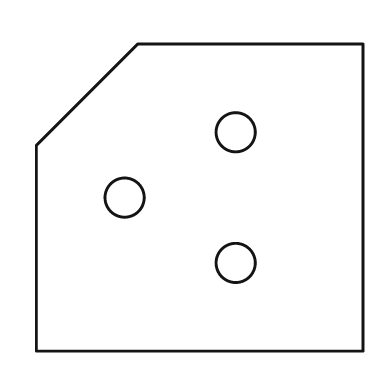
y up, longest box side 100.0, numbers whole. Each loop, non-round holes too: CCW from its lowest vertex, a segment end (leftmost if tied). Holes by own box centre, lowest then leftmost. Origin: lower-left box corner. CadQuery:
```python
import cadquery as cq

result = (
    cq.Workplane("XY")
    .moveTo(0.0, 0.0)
    .lineTo(100.0, 0.0)
    .lineTo(100.0, 94.0)
    .lineTo(31.0, 94.0)
    .lineTo(0.0, 63.0)
    .close()
    .moveTo(61.0, 27.0)
    .circle(6.0)
    .moveTo(27.0, 47.0)
    .circle(6.0)
    .moveTo(61.0, 67.0)
    .circle(6.0)
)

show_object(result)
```